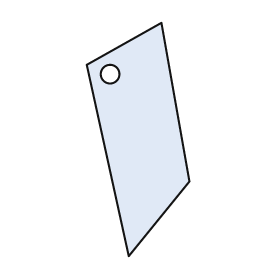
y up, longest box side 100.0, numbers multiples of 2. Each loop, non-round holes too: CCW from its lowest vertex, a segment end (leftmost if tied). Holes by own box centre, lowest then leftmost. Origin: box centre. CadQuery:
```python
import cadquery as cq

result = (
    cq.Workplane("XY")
    .moveTo(-4.0, -50.0)
    .lineTo(22.0, -18.0)
    .lineTo(10.0, 50.0)
    .lineTo(-22.0, 32.0)
    .close()
    .moveTo(-12.0, 28.0)
    .circle(4.0)
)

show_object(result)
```